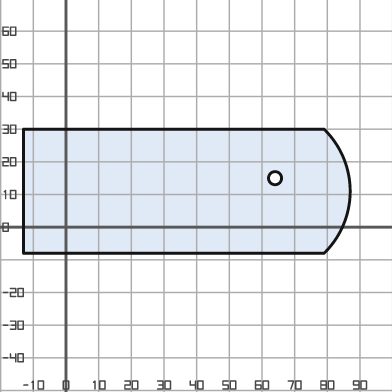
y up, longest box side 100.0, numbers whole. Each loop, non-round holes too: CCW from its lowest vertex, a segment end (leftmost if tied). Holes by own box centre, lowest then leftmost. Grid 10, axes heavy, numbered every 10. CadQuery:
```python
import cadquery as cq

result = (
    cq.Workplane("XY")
    .moveTo(-13.0, -8.0)
    .lineTo(79.0, -8.0)
    .threePointArc((87.0, 11.0), (79.0, 30.0))
    .lineTo(-13.0, 30.0)
    .close()
    .moveTo(64.0, 15.0)
    .circle(2.0)
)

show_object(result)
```